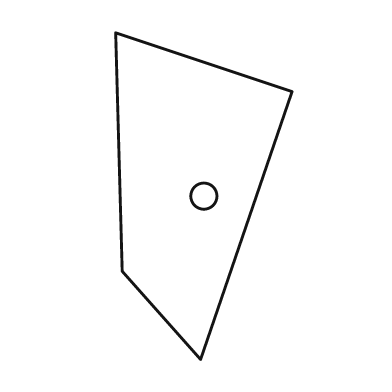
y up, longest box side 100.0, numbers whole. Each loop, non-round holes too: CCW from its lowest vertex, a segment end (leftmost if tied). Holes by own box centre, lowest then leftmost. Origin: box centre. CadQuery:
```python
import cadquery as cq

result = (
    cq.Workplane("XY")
    .moveTo(-1.0, -50.0)
    .lineTo(27.0, 32.0)
    .lineTo(-27.0, 50.0)
    .lineTo(-25.0, -23.0)
    .close()
    .moveTo(0.0, 0.0)
    .circle(4.0)
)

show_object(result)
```